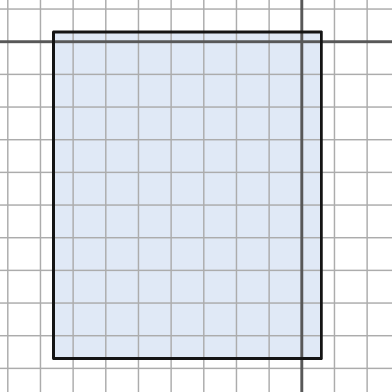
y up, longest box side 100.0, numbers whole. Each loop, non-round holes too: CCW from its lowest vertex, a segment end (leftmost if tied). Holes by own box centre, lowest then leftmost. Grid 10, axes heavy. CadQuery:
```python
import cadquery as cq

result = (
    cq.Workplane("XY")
    .moveTo(-76.0, -97.0)
    .lineTo(6.0, -97.0)
    .lineTo(6.0, 3.0)
    .lineTo(-76.0, 3.0)
    .close()
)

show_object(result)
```